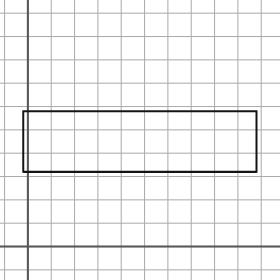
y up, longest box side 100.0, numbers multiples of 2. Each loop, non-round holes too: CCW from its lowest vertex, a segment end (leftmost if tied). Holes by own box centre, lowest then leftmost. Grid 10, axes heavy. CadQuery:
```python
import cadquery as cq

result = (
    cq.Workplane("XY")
    .moveTo(-2.0, 32.0)
    .lineTo(98.0, 32.0)
    .lineTo(98.0, 58.0)
    .lineTo(-2.0, 58.0)
    .close()
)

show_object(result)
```